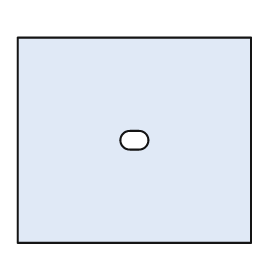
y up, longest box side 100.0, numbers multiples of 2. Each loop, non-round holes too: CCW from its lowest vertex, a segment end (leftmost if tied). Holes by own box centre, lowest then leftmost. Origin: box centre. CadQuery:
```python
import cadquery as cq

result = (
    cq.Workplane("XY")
    .moveTo(-50.0, -44.0)
    .lineTo(50.0, -44.0)
    .lineTo(50.0, 44.0)
    .lineTo(-50.0, 44.0)
    .close()
    .moveTo(-2.0, -4.0)
    .lineTo(2.0, -4.0)
    .threePointArc((6.0, 0.0), (2.0, 4.0))
    .lineTo(-2.0, 4.0)
    .threePointArc((-6.0, 0.0), (-2.0, -4.0))
    .close()
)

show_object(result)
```